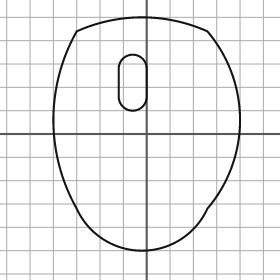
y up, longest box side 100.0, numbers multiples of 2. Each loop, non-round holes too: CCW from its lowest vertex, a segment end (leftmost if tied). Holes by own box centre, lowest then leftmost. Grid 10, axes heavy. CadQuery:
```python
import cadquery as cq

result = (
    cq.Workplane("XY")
    .moveTo(-30.0, -32.0)
    .threePointArc((-2.0, -50.0), (26.0, -32.0))
    .threePointArc((40.0, 6.0), (26.0, 44.0))
    .threePointArc((-2.0, 50.0), (-30.0, 44.0))
    .threePointArc((-40.0, 6.0), (-30.0, -32.0))
    .close()
    .moveTo(-12.0, 16.0)
    .threePointArc((-6.0, 10.0), (0.0, 16.0))
    .lineTo(0.0, 28.0)
    .threePointArc((-6.0, 34.0), (-12.0, 28.0))
    .close()
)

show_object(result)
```